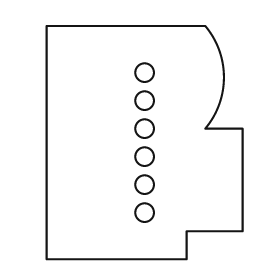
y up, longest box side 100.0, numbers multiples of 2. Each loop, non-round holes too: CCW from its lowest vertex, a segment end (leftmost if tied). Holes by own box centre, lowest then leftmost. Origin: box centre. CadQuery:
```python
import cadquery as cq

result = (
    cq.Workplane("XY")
    .moveTo(-42.0, -50.0)
    .lineTo(18.0, -50.0)
    .lineTo(18.0, -38.0)
    .lineTo(42.0, -38.0)
    .lineTo(42.0, 6.0)
    .lineTo(26.0, 6.0)
    .threePointArc((34.0, 28.0), (26.0, 50.0))
    .lineTo(-42.0, 50.0)
    .close()
    .moveTo(0.0, -30.0)
    .circle(4.0)
    .moveTo(0.0, -18.0)
    .circle(4.0)
    .moveTo(0.0, -6.0)
    .circle(4.0)
    .moveTo(0.0, 6.0)
    .circle(4.0)
    .moveTo(0.0, 18.0)
    .circle(4.0)
    .moveTo(0.0, 30.0)
    .circle(4.0)
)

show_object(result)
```